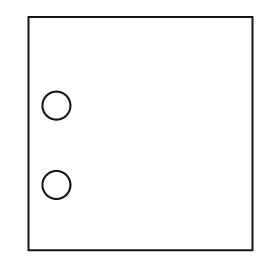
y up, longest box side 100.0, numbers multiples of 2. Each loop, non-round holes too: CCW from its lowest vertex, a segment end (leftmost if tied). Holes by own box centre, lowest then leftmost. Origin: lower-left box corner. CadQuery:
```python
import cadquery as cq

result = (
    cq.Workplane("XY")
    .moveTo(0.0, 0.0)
    .lineTo(96.0, 0.0)
    .lineTo(96.0, 100.0)
    .lineTo(0.0, 100.0)
    .close()
    .moveTo(12.0, 28.0)
    .circle(6.0)
    .moveTo(12.0, 62.0)
    .circle(6.0)
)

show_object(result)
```